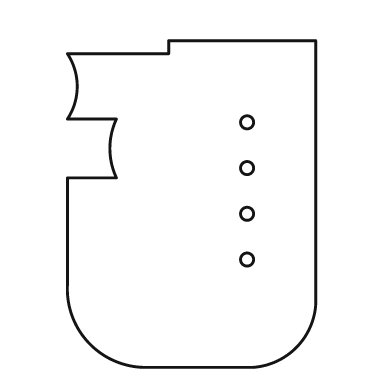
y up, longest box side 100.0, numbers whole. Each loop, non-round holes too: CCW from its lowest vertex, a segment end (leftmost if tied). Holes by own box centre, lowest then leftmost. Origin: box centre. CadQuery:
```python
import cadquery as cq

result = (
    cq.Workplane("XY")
    .moveTo(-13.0, -50.0)
    .lineTo(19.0, -50.0)
    .threePointArc((32.0, -44.0), (38.0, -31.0))
    .lineTo(38.0, 50.0)
    .lineTo(-7.0, 50.0)
    .lineTo(-7.0, 46.0)
    .lineTo(-38.0, 46.0)
    .threePointArc((-35.0, 36.0), (-38.0, 26.0))
    .lineTo(-23.0, 26.0)
    .threePointArc((-25.0, 17.0), (-23.0, 8.0))
    .lineTo(-38.0, 8.0)
    .lineTo(-38.0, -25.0)
    .threePointArc((-31.0, -43.0), (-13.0, -50.0))
    .close()
    .moveTo(17.0, -17.0)
    .circle(2.0)
    .moveTo(17.0, -3.0)
    .circle(2.0)
    .moveTo(17.0, 11.0)
    .circle(2.0)
    .moveTo(17.0, 25.0)
    .circle(2.0)
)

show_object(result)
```